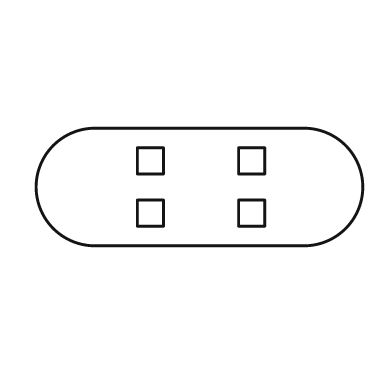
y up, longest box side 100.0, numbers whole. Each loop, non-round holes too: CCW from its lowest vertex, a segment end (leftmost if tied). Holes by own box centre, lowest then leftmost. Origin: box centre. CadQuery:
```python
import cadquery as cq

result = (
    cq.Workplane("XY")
    .moveTo(-32.0, -18.0)
    .lineTo(32.0, -18.0)
    .threePointArc((50.0, 0.0), (32.0, 18.0))
    .lineTo(-32.0, 18.0)
    .threePointArc((-50.0, 0.0), (-32.0, -18.0))
    .close()
    .moveTo(-19.0, -12.0)
    .lineTo(-11.0, -12.0)
    .lineTo(-11.0, -4.0)
    .lineTo(-19.0, -4.0)
    .close()
    .moveTo(12.0, -12.0)
    .lineTo(20.0, -12.0)
    .lineTo(20.0, -4.0)
    .lineTo(12.0, -4.0)
    .close()
    .moveTo(-19.0, 4.0)
    .lineTo(-11.0, 4.0)
    .lineTo(-11.0, 12.0)
    .lineTo(-19.0, 12.0)
    .close()
    .moveTo(12.0, 4.0)
    .lineTo(20.0, 4.0)
    .lineTo(20.0, 12.0)
    .lineTo(12.0, 12.0)
    .close()
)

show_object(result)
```